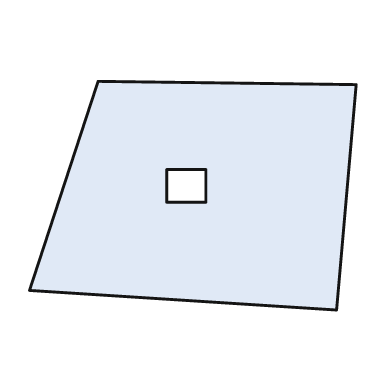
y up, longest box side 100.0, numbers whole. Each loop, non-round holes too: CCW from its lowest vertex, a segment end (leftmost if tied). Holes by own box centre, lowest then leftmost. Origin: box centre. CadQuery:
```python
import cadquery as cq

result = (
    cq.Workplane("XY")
    .moveTo(44.0, -35.0)
    .lineTo(50.0, 34.0)
    .lineTo(-29.0, 35.0)
    .lineTo(-50.0, -29.0)
    .close()
    .moveTo(-8.0, -2.0)
    .lineTo(4.0, -2.0)
    .lineTo(4.0, 8.0)
    .lineTo(-8.0, 8.0)
    .close()
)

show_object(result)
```